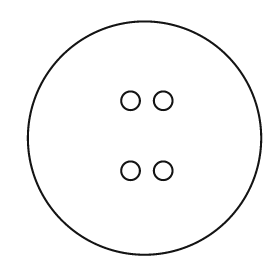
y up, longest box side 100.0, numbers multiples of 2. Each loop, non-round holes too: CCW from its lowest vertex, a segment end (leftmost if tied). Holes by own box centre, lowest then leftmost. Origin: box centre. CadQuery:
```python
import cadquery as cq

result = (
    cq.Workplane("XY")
    .moveTo(0.0, 0.0)
    .circle(50.0)
    .moveTo(-6.0, -14.0)
    .circle(4.0)
    .moveTo(8.0, -14.0)
    .circle(4.0)
    .moveTo(-6.0, 16.0)
    .circle(4.0)
    .moveTo(8.0, 16.0)
    .circle(4.0)
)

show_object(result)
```